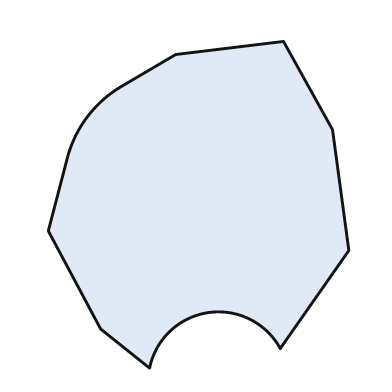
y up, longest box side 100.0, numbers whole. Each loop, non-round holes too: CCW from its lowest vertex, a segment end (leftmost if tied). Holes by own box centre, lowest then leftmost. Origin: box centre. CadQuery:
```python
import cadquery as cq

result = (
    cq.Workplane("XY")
    .moveTo(-15.0, -50.0)
    .threePointArc((3.0, -33.0), (25.0, -44.0))
    .lineTo(46.0, -14.0)
    .lineTo(41.0, 23.0)
    .lineTo(26.0, 50.0)
    .lineTo(-7.0, 46.0)
    .lineTo(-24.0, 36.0)
    .threePointArc((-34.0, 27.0), (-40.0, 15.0))
    .lineTo(-46.0, -8.0)
    .lineTo(-30.0, -38.0)
    .close()
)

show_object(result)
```